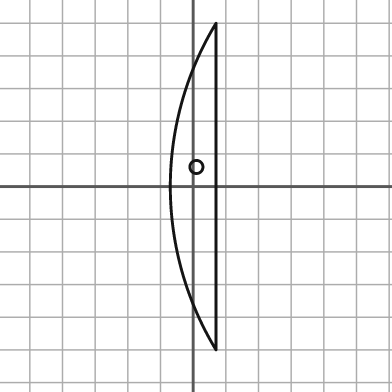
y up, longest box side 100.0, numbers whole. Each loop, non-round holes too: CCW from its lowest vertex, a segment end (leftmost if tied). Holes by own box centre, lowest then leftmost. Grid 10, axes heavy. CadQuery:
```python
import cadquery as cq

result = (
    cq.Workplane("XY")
    .moveTo(7.0, -50.0)
    .lineTo(7.0, 50.0)
    .threePointArc((-7.0, 0.0), (7.0, -50.0))
    .close()
    .moveTo(1.0, 6.0)
    .circle(2.0)
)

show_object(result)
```